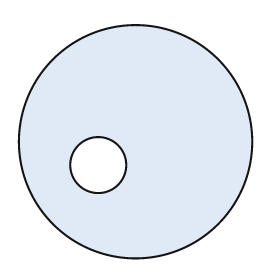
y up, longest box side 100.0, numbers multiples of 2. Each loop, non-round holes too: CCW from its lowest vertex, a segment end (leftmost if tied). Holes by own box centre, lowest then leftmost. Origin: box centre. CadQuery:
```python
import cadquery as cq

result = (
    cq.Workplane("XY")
    .moveTo(0.0, 0.0)
    .circle(50.0)
    .moveTo(-16.0, -10.0)
    .circle(12.0)
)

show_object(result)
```